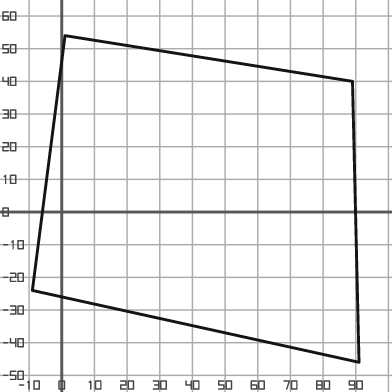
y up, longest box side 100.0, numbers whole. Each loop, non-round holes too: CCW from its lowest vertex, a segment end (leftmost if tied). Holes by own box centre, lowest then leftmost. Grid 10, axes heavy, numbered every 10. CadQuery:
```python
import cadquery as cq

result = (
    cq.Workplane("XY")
    .moveTo(91.0, -46.0)
    .lineTo(89.0, 40.0)
    .lineTo(1.0, 54.0)
    .lineTo(-9.0, -24.0)
    .close()
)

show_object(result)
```